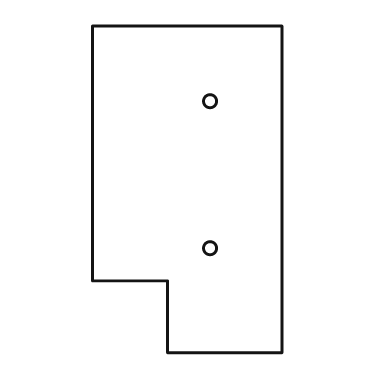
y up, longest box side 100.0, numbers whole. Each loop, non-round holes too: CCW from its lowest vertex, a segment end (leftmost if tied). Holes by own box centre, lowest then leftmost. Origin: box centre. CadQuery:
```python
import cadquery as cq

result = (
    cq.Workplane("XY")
    .moveTo(-6.0, -50.0)
    .lineTo(29.0, -50.0)
    .lineTo(29.0, 50.0)
    .lineTo(-29.0, 50.0)
    .lineTo(-29.0, -28.0)
    .lineTo(-6.0, -28.0)
    .close()
    .moveTo(7.0, -18.0)
    .circle(2.0)
    .moveTo(7.0, 27.0)
    .circle(2.0)
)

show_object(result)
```